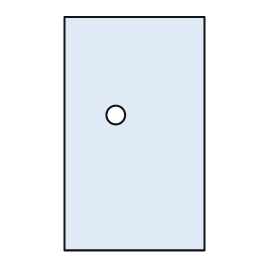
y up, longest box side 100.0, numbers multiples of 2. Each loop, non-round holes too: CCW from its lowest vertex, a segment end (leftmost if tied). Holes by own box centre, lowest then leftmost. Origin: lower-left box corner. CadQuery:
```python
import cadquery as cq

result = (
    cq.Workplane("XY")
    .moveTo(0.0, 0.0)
    .lineTo(60.0, 0.0)
    .lineTo(60.0, 100.0)
    .lineTo(0.0, 100.0)
    .close()
    .moveTo(22.0, 58.0)
    .circle(4.0)
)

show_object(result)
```